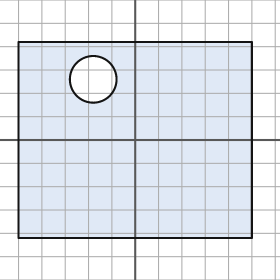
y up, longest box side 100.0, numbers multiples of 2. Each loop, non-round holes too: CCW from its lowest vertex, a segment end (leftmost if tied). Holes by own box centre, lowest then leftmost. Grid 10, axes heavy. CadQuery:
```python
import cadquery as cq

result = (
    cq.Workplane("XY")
    .moveTo(-50.0, -42.0)
    .lineTo(50.0, -42.0)
    .lineTo(50.0, 42.0)
    .lineTo(-50.0, 42.0)
    .close()
    .moveTo(-18.0, 26.0)
    .circle(10.0)
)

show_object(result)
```